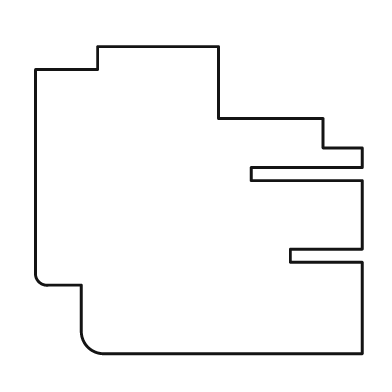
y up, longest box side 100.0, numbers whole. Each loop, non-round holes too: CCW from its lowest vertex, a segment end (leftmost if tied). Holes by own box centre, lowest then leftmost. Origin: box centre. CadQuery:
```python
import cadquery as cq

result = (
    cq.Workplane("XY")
    .moveTo(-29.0, -47.0)
    .lineTo(50.0, -47.0)
    .lineTo(50.0, -19.0)
    .lineTo(28.0, -19.0)
    .lineTo(28.0, -15.0)
    .lineTo(50.0, -15.0)
    .lineTo(50.0, 6.0)
    .lineTo(16.0, 6.0)
    .lineTo(16.0, 10.0)
    .lineTo(50.0, 10.0)
    .lineTo(50.0, 16.0)
    .lineTo(38.0, 16.0)
    .lineTo(38.0, 25.0)
    .lineTo(6.0, 25.0)
    .lineTo(6.0, 47.0)
    .lineTo(-31.0, 47.0)
    .lineTo(-31.0, 40.0)
    .lineTo(-50.0, 40.0)
    .lineTo(-50.0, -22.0)
    .threePointArc((-49.0, -25.0), (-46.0, -26.0))
    .lineTo(-36.0, -26.0)
    .lineTo(-36.0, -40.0)
    .threePointArc((-34.0, -45.0), (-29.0, -47.0))
    .close()
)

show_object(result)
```